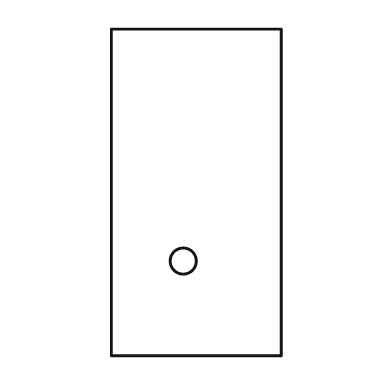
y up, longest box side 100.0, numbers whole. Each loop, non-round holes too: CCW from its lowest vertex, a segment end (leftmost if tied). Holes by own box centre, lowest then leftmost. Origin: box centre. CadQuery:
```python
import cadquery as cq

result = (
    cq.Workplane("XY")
    .moveTo(-26.0, -50.0)
    .lineTo(26.0, -50.0)
    .lineTo(26.0, 50.0)
    .lineTo(-26.0, 50.0)
    .close()
    .moveTo(-4.0, -21.0)
    .circle(4.0)
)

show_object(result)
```